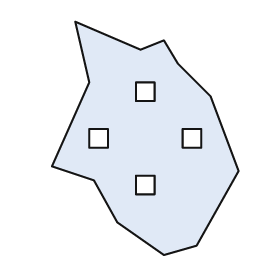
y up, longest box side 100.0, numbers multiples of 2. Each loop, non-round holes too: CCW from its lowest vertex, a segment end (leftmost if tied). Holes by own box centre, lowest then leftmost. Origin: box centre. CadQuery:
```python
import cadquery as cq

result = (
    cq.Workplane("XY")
    .moveTo(8.0, -50.0)
    .lineTo(22.0, -46.0)
    .lineTo(40.0, -14.0)
    .lineTo(28.0, 18.0)
    .lineTo(14.0, 32.0)
    .lineTo(8.0, 42.0)
    .lineTo(-2.0, 38.0)
    .lineTo(-30.0, 50.0)
    .lineTo(-24.0, 24.0)
    .lineTo(-40.0, -12.0)
    .lineTo(-22.0, -18.0)
    .lineTo(-12.0, -36.0)
    .close()
    .moveTo(-4.0, -24.0)
    .lineTo(4.0, -24.0)
    .lineTo(4.0, -16.0)
    .lineTo(-4.0, -16.0)
    .close()
    .moveTo(-24.0, -4.0)
    .lineTo(-16.0, -4.0)
    .lineTo(-16.0, 4.0)
    .lineTo(-24.0, 4.0)
    .close()
    .moveTo(16.0, -4.0)
    .lineTo(24.0, -4.0)
    .lineTo(24.0, 4.0)
    .lineTo(16.0, 4.0)
    .close()
    .moveTo(-4.0, 16.0)
    .lineTo(4.0, 16.0)
    .lineTo(4.0, 24.0)
    .lineTo(-4.0, 24.0)
    .close()
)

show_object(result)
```